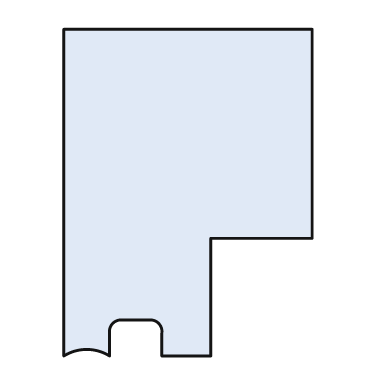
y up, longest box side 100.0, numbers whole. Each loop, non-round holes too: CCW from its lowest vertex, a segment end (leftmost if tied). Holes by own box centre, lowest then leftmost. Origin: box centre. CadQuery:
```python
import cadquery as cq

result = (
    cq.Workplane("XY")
    .moveTo(-38.0, -50.0)
    .threePointArc((-31.0, -48.0), (-24.0, -50.0))
    .lineTo(-24.0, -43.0)
    .threePointArc((-23.0, -40.0), (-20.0, -39.0))
    .lineTo(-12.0, -39.0)
    .threePointArc((-9.0, -40.0), (-8.0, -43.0))
    .lineTo(-8.0, -50.0)
    .lineTo(7.0, -50.0)
    .lineTo(7.0, -14.0)
    .lineTo(38.0, -14.0)
    .lineTo(38.0, 50.0)
    .lineTo(-38.0, 50.0)
    .close()
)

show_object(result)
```